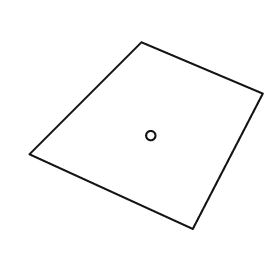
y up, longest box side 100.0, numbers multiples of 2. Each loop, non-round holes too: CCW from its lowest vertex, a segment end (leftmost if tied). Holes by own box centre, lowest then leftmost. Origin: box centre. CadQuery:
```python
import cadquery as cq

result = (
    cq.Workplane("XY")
    .moveTo(20.0, -40.0)
    .lineTo(50.0, 18.0)
    .lineTo(-2.0, 40.0)
    .lineTo(-50.0, -8.0)
    .close()
    .moveTo(2.0, 0.0)
    .circle(2.0)
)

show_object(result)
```